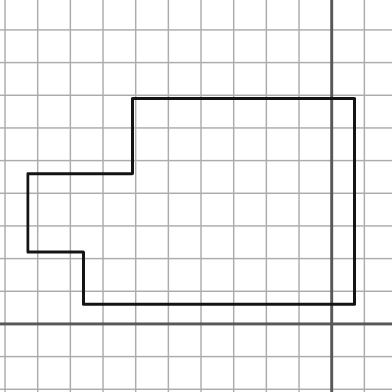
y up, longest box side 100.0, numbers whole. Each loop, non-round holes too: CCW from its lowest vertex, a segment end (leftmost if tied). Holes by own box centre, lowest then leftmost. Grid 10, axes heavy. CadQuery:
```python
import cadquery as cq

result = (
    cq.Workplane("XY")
    .moveTo(-76.0, 6.0)
    .lineTo(7.0, 6.0)
    .lineTo(7.0, 69.0)
    .lineTo(-61.0, 69.0)
    .lineTo(-61.0, 46.0)
    .lineTo(-93.0, 46.0)
    .lineTo(-93.0, 22.0)
    .lineTo(-76.0, 22.0)
    .close()
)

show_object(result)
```